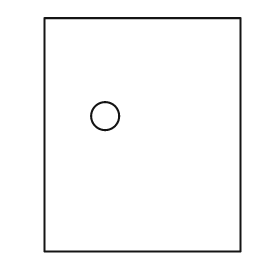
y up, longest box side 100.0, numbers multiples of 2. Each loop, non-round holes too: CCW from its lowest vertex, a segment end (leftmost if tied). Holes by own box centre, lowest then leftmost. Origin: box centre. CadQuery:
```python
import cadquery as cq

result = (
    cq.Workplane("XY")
    .moveTo(-42.0, -50.0)
    .lineTo(42.0, -50.0)
    .lineTo(42.0, 50.0)
    .lineTo(-42.0, 50.0)
    .close()
    .moveTo(-16.0, 8.0)
    .circle(6.0)
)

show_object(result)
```